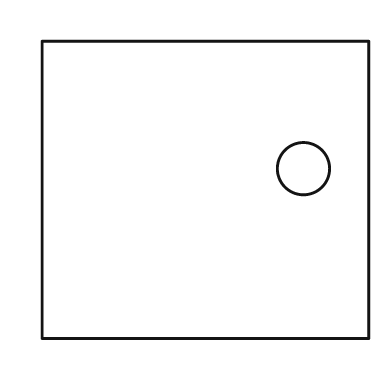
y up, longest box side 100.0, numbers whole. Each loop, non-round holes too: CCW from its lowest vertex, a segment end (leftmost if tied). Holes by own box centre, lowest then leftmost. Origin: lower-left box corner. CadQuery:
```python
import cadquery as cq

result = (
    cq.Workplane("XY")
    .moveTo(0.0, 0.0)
    .lineTo(100.0, 0.0)
    .lineTo(100.0, 91.0)
    .lineTo(0.0, 91.0)
    .close()
    .moveTo(80.0, 52.0)
    .circle(8.0)
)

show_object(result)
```